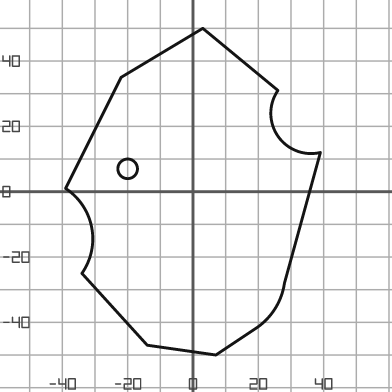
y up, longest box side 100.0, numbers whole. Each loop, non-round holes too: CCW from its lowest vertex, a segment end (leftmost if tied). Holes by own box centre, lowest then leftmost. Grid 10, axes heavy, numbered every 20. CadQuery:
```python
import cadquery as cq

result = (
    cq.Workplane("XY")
    .moveTo(7.0, -50.0)
    .lineTo(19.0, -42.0)
    .threePointArc((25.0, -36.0), (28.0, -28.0))
    .lineTo(39.0, 12.0)
    .threePointArc((26.0, 17.0), (26.0, 31.0))
    .lineTo(3.0, 50.0)
    .lineTo(-22.0, 35.0)
    .lineTo(-39.0, 1.0)
    .threePointArc((-31.0, -11.0), (-34.0, -25.0))
    .lineTo(-14.0, -47.0)
    .close()
    .moveTo(-20.0, 7.0)
    .circle(3.0)
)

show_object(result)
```